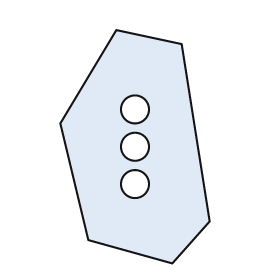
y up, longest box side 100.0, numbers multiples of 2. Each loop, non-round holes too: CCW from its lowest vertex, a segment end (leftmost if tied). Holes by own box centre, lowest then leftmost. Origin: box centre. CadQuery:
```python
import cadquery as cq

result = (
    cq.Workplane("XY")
    .moveTo(16.0, -50.0)
    .lineTo(32.0, -32.0)
    .lineTo(20.0, 44.0)
    .lineTo(-8.0, 50.0)
    .lineTo(-32.0, 10.0)
    .lineTo(-20.0, -40.0)
    .close()
    .moveTo(0.0, -16.0)
    .circle(6.0)
    .moveTo(0.0, 0.0)
    .circle(6.0)
    .moveTo(0.0, 16.0)
    .circle(6.0)
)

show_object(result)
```